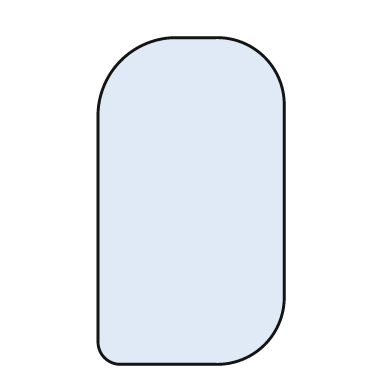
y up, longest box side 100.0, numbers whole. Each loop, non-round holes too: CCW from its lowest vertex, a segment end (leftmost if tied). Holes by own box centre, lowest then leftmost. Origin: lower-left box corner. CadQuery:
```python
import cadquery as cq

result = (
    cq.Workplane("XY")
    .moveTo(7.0, 0.0)
    .lineTo(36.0, 0.0)
    .threePointArc((51.0, 6.0), (57.0, 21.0))
    .lineTo(57.0, 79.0)
    .threePointArc((51.0, 94.0), (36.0, 100.0))
    .lineTo(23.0, 100.0)
    .threePointArc((7.0, 93.0), (0.0, 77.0))
    .lineTo(0.0, 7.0)
    .threePointArc((2.0, 2.0), (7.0, 0.0))
    .close()
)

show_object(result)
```